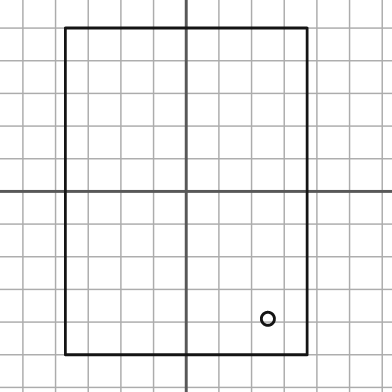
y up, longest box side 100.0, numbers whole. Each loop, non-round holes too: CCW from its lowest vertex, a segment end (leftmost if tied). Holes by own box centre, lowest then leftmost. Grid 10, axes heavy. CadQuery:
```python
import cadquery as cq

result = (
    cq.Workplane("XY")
    .moveTo(-37.0, -50.0)
    .lineTo(37.0, -50.0)
    .lineTo(37.0, 50.0)
    .lineTo(-37.0, 50.0)
    .close()
    .moveTo(25.0, -39.0)
    .circle(2.0)
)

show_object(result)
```